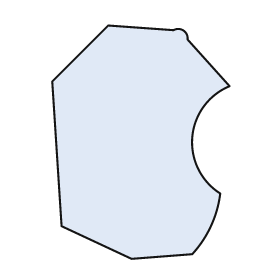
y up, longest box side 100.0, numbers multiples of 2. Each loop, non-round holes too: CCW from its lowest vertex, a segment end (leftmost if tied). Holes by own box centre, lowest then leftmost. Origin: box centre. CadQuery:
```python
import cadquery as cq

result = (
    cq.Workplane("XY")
    .moveTo(-4.0, -50.0)
    .lineTo(22.0, -48.0)
    .threePointArc((30.0, -36.0), (34.0, -22.0))
    .threePointArc((22.0, 2.0), (38.0, 24.0))
    .lineTo(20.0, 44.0)
    .threePointArc((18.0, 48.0), (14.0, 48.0))
    .lineTo(-14.0, 50.0)
    .lineTo(-38.0, 26.0)
    .lineTo(-34.0, -36.0)
    .close()
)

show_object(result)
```